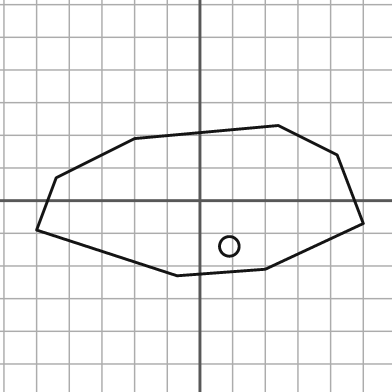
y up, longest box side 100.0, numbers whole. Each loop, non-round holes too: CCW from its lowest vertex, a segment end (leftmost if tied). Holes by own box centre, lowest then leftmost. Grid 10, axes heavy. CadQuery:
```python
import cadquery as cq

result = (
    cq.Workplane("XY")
    .moveTo(-7.0, -23.0)
    .lineTo(20.0, -21.0)
    .lineTo(50.0, -7.0)
    .lineTo(42.0, 14.0)
    .lineTo(24.0, 23.0)
    .lineTo(-20.0, 19.0)
    .lineTo(-44.0, 7.0)
    .lineTo(-50.0, -9.0)
    .close()
    .moveTo(9.0, -14.0)
    .circle(3.0)
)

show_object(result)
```